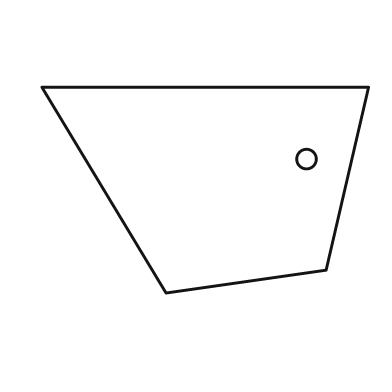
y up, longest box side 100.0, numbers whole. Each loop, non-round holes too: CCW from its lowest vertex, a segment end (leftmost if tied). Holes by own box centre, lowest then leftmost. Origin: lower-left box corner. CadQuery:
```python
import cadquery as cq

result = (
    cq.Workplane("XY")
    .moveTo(38.0, 0.0)
    .lineTo(87.0, 7.0)
    .lineTo(100.0, 63.0)
    .lineTo(0.0, 63.0)
    .close()
    .moveTo(81.0, 41.0)
    .circle(3.0)
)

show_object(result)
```